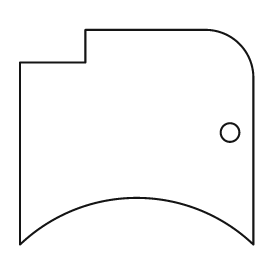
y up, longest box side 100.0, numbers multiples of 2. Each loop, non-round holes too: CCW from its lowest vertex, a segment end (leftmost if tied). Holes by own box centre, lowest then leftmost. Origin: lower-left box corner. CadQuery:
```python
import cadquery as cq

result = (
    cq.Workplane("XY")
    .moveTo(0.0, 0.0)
    .threePointArc((50.0, 20.0), (100.0, 0.0))
    .lineTo(100.0, 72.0)
    .threePointArc((94.0, 86.0), (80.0, 92.0))
    .lineTo(28.0, 92.0)
    .lineTo(28.0, 78.0)
    .lineTo(0.0, 78.0)
    .close()
    .moveTo(90.0, 48.0)
    .circle(4.0)
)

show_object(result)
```